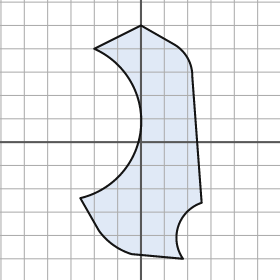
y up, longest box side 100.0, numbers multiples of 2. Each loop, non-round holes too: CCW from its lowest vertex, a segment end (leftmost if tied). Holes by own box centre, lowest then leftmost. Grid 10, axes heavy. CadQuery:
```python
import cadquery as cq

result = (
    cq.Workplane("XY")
    .moveTo(18.0, -50.0)
    .threePointArc((16.0, -36.0), (26.0, -26.0))
    .lineTo(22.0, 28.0)
    .threePointArc((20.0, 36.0), (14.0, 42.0))
    .lineTo(0.0, 50.0)
    .lineTo(-20.0, 40.0)
    .threePointArc((0.0, 6.0), (-26.0, -24.0))
    .lineTo(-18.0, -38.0)
    .threePointArc((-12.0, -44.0), (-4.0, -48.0))
    .close()
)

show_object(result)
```